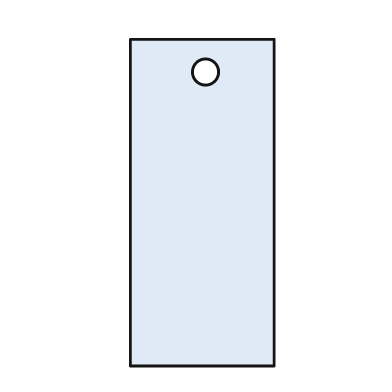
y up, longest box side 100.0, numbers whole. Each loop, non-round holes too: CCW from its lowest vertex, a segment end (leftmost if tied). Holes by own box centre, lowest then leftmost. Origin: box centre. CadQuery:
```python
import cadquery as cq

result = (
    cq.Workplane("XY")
    .moveTo(-22.0, -50.0)
    .lineTo(22.0, -50.0)
    .lineTo(22.0, 50.0)
    .lineTo(-22.0, 50.0)
    .close()
    .moveTo(1.0, 40.0)
    .circle(4.0)
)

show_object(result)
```